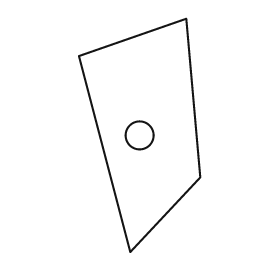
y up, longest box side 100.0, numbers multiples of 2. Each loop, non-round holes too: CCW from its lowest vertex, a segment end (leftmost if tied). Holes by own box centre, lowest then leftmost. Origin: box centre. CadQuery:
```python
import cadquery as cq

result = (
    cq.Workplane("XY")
    .moveTo(-4.0, -50.0)
    .lineTo(26.0, -18.0)
    .lineTo(20.0, 50.0)
    .lineTo(-26.0, 34.0)
    .close()
    .moveTo(0.0, 0.0)
    .circle(6.0)
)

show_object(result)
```